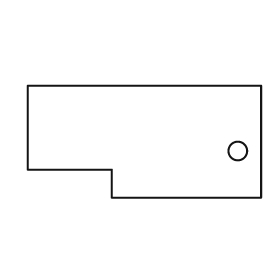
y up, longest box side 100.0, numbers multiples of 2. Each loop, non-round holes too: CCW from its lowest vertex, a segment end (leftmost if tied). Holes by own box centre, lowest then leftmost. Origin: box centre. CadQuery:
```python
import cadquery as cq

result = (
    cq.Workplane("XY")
    .moveTo(-14.0, -24.0)
    .lineTo(50.0, -24.0)
    .lineTo(50.0, 24.0)
    .lineTo(-50.0, 24.0)
    .lineTo(-50.0, -12.0)
    .lineTo(-14.0, -12.0)
    .close()
    .moveTo(40.0, -4.0)
    .circle(4.0)
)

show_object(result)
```